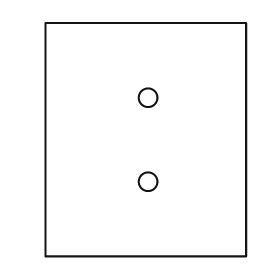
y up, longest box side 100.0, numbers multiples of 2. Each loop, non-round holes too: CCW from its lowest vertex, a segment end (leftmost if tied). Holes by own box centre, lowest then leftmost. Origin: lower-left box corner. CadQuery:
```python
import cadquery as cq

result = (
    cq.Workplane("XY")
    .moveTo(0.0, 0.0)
    .lineTo(86.0, 0.0)
    .lineTo(86.0, 100.0)
    .lineTo(0.0, 100.0)
    .close()
    .moveTo(44.0, 32.0)
    .circle(4.0)
    .moveTo(44.0, 68.0)
    .circle(4.0)
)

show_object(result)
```